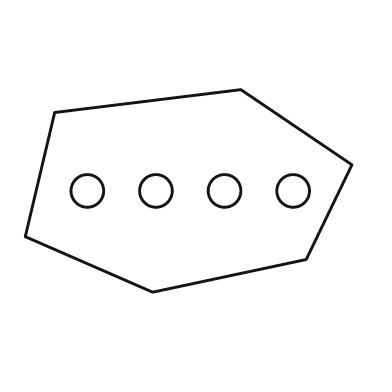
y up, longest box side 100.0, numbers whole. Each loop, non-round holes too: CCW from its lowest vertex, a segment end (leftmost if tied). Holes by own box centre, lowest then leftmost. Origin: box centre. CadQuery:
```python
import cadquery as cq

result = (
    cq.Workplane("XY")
    .moveTo(-11.0, -31.0)
    .lineTo(36.0, -21.0)
    .lineTo(50.0, 8.0)
    .lineTo(16.0, 31.0)
    .lineTo(-41.0, 24.0)
    .lineTo(-50.0, -14.0)
    .close()
    .moveTo(-31.0, 0.0)
    .circle(5.0)
    .moveTo(-10.0, 0.0)
    .circle(5.0)
    .moveTo(11.0, 0.0)
    .circle(5.0)
    .moveTo(32.0, 0.0)
    .circle(5.0)
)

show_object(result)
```